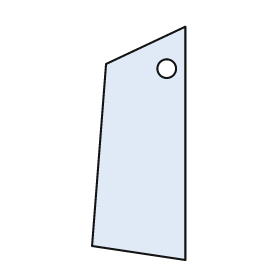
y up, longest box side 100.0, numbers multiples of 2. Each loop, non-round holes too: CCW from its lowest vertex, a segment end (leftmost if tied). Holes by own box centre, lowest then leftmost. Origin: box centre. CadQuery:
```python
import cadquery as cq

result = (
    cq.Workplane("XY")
    .moveTo(20.0, -50.0)
    .lineTo(20.0, 50.0)
    .lineTo(-14.0, 34.0)
    .lineTo(-20.0, -44.0)
    .close()
    .moveTo(12.0, 32.0)
    .circle(4.0)
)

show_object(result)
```